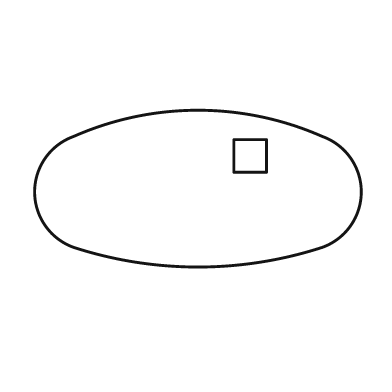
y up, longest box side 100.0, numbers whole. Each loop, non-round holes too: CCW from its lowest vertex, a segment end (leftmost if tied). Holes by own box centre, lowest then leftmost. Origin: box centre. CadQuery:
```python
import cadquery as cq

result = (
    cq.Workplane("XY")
    .moveTo(-38.0, -18.0)
    .threePointArc((0.0, -24.0), (38.0, -18.0))
    .threePointArc((50.0, -1.0), (38.0, 16.0))
    .threePointArc((0.0, 24.0), (-38.0, 16.0))
    .threePointArc((-50.0, -1.0), (-38.0, -18.0))
    .close()
    .moveTo(11.0, 5.0)
    .lineTo(21.0, 5.0)
    .lineTo(21.0, 15.0)
    .lineTo(11.0, 15.0)
    .close()
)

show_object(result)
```